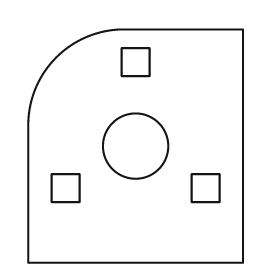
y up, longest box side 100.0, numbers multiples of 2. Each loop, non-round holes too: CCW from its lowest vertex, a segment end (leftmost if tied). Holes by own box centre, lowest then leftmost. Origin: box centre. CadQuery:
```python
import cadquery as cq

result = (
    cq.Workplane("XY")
    .moveTo(-46.0, -50.0)
    .lineTo(46.0, -50.0)
    .lineTo(46.0, 50.0)
    .lineTo(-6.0, 50.0)
    .threePointArc((-34.0, 38.0), (-46.0, 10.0))
    .close()
    .moveTo(-36.0, -24.0)
    .lineTo(-24.0, -24.0)
    .lineTo(-24.0, -12.0)
    .lineTo(-36.0, -12.0)
    .close()
    .moveTo(24.0, -24.0)
    .lineTo(36.0, -24.0)
    .lineTo(36.0, -12.0)
    .lineTo(24.0, -12.0)
    .close()
    .moveTo(0.0, 0.0)
    .circle(14.0)
    .moveTo(-6.0, 30.0)
    .lineTo(6.0, 30.0)
    .lineTo(6.0, 42.0)
    .lineTo(-6.0, 42.0)
    .close()
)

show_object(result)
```